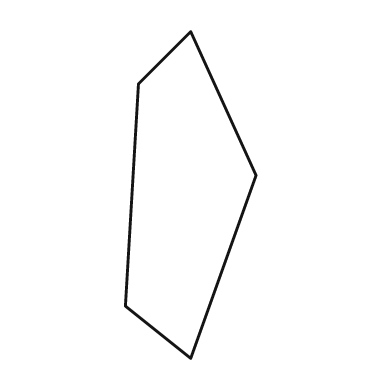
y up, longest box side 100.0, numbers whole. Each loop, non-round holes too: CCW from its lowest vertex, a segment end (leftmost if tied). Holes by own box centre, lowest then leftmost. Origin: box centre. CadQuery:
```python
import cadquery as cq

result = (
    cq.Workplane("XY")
    .moveTo(0.0, -50.0)
    .lineTo(20.0, 6.0)
    .lineTo(0.0, 50.0)
    .lineTo(-16.0, 34.0)
    .lineTo(-20.0, -34.0)
    .close()
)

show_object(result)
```